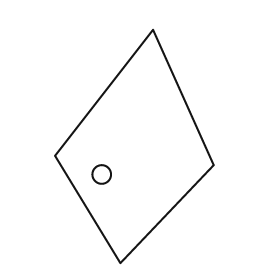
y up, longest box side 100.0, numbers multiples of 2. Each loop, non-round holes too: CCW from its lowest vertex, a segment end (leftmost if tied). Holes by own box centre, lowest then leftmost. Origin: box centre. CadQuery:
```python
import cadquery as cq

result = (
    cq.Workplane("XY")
    .moveTo(-6.0, -50.0)
    .lineTo(34.0, -8.0)
    .lineTo(8.0, 50.0)
    .lineTo(-34.0, -4.0)
    .close()
    .moveTo(-14.0, -12.0)
    .circle(4.0)
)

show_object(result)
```